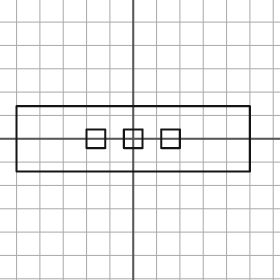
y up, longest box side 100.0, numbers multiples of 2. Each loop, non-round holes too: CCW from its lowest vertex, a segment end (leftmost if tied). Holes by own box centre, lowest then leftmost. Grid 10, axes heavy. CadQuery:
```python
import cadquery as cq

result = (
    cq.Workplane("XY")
    .moveTo(-50.0, -14.0)
    .lineTo(50.0, -14.0)
    .lineTo(50.0, 14.0)
    .lineTo(-50.0, 14.0)
    .close()
    .moveTo(-20.0, -4.0)
    .lineTo(-12.0, -4.0)
    .lineTo(-12.0, 4.0)
    .lineTo(-20.0, 4.0)
    .close()
    .moveTo(-4.0, -4.0)
    .lineTo(4.0, -4.0)
    .lineTo(4.0, 4.0)
    .lineTo(-4.0, 4.0)
    .close()
    .moveTo(12.0, -4.0)
    .lineTo(20.0, -4.0)
    .lineTo(20.0, 4.0)
    .lineTo(12.0, 4.0)
    .close()
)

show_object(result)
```